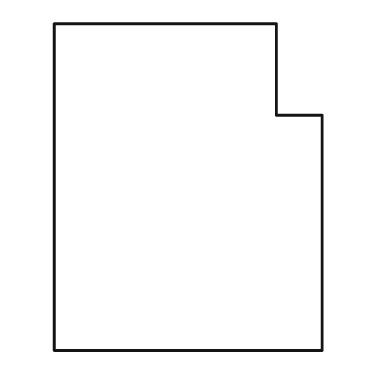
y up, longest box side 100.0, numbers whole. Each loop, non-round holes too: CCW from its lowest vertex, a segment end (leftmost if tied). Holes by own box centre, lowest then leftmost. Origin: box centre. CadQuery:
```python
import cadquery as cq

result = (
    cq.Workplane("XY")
    .moveTo(-41.0, -50.0)
    .lineTo(41.0, -50.0)
    .lineTo(41.0, 22.0)
    .lineTo(27.0, 22.0)
    .lineTo(27.0, 50.0)
    .lineTo(-41.0, 50.0)
    .close()
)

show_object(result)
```